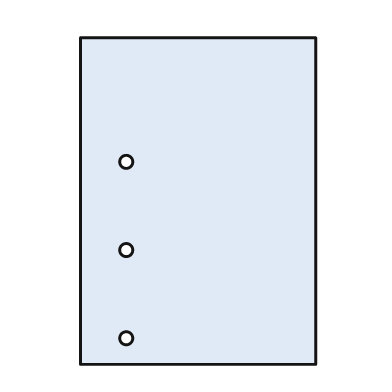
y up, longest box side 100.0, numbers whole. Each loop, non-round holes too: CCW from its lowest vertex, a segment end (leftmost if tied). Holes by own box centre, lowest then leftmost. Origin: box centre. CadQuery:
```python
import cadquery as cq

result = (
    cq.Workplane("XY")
    .moveTo(-36.0, -50.0)
    .lineTo(36.0, -50.0)
    .lineTo(36.0, 50.0)
    .lineTo(-36.0, 50.0)
    .close()
    .moveTo(-22.0, -42.0)
    .circle(2.0)
    .moveTo(-22.0, -15.0)
    .circle(2.0)
    .moveTo(-22.0, 12.0)
    .circle(2.0)
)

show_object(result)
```